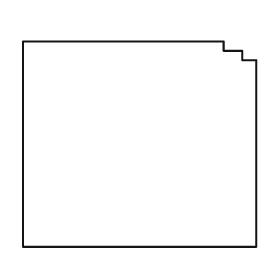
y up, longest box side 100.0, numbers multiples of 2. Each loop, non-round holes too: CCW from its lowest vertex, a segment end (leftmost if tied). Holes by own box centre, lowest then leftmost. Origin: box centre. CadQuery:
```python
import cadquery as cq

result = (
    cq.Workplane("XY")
    .moveTo(-50.0, -44.0)
    .lineTo(50.0, -44.0)
    .lineTo(50.0, 36.0)
    .lineTo(44.0, 36.0)
    .lineTo(44.0, 40.0)
    .lineTo(36.0, 40.0)
    .lineTo(36.0, 44.0)
    .lineTo(-50.0, 44.0)
    .close()
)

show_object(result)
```